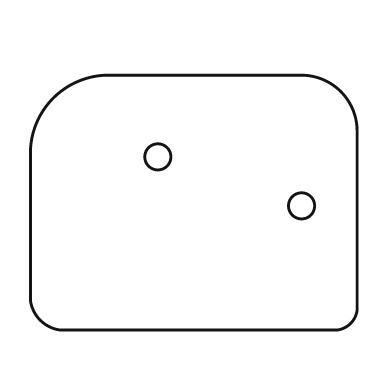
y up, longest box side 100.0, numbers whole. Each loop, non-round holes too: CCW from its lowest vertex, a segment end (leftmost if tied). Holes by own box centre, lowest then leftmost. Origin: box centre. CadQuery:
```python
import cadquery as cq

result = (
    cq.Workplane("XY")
    .moveTo(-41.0, -39.0)
    .lineTo(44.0, -39.0)
    .threePointArc((48.0, -37.0), (50.0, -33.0))
    .lineTo(50.0, 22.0)
    .threePointArc((45.0, 34.0), (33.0, 39.0))
    .lineTo(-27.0, 39.0)
    .threePointArc((-43.0, 32.0), (-50.0, 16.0))
    .lineTo(-50.0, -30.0)
    .threePointArc((-47.0, -36.0), (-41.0, -39.0))
    .close()
    .moveTo(33.0, -1.0)
    .circle(4.0)
    .moveTo(-11.0, 14.0)
    .circle(4.0)
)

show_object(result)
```